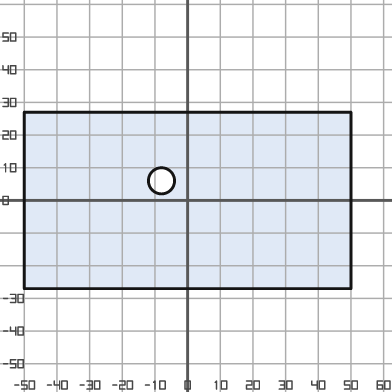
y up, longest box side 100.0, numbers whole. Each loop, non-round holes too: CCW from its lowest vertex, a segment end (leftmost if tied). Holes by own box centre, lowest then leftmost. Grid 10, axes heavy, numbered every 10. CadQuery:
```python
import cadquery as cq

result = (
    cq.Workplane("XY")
    .moveTo(-50.0, -27.0)
    .lineTo(50.0, -27.0)
    .lineTo(50.0, 27.0)
    .lineTo(-50.0, 27.0)
    .close()
    .moveTo(-8.0, 6.0)
    .circle(4.0)
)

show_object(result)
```